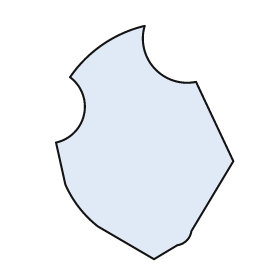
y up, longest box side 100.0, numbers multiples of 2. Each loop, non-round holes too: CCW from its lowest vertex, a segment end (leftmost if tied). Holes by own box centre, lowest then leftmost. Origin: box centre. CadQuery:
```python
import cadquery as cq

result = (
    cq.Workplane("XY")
    .moveTo(4.0, -50.0)
    .lineTo(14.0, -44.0)
    .threePointArc((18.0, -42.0), (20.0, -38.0))
    .lineTo(38.0, -8.0)
    .lineTo(22.0, 26.0)
    .threePointArc((4.0, 32.0), (0.0, 50.0))
    .threePointArc((-18.0, 42.0), (-32.0, 28.0))
    .threePointArc((-26.0, 12.0), (-38.0, 0.0))
    .lineTo(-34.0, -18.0)
    .threePointArc((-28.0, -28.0), (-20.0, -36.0))
    .close()
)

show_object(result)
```